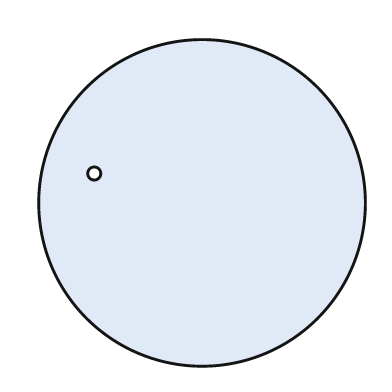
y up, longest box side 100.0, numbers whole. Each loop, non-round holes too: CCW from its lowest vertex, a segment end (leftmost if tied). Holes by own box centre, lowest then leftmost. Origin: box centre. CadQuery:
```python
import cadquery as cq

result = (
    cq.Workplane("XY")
    .moveTo(0.0, 0.0)
    .circle(50.0)
    .moveTo(-33.0, 9.0)
    .circle(2.0)
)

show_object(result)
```